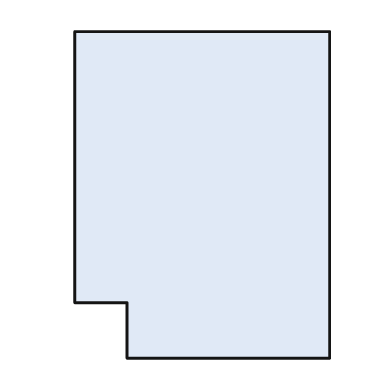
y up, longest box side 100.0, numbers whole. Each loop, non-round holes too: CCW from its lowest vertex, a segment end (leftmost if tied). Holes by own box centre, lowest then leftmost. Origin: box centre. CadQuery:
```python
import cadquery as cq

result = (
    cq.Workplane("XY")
    .moveTo(-23.0, -50.0)
    .lineTo(39.0, -50.0)
    .lineTo(39.0, 50.0)
    .lineTo(-39.0, 50.0)
    .lineTo(-39.0, -33.0)
    .lineTo(-23.0, -33.0)
    .close()
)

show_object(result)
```